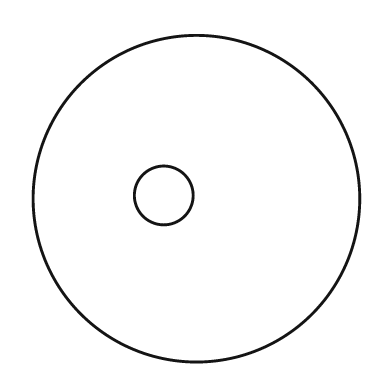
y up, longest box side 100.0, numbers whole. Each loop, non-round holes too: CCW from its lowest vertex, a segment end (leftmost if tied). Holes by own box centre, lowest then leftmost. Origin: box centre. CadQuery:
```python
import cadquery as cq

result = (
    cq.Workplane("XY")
    .moveTo(0.0, 0.0)
    .circle(50.0)
    .moveTo(-10.0, 1.0)
    .circle(9.0)
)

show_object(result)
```